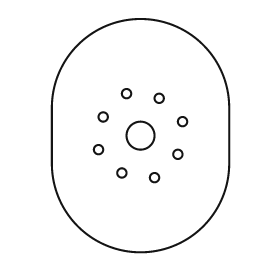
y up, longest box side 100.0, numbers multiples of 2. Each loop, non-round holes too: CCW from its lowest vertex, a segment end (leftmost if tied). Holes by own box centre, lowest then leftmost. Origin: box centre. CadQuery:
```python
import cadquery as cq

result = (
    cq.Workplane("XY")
    .moveTo(-38.0, -12.0)
    .threePointArc((0.0, -50.0), (38.0, -12.0))
    .lineTo(38.0, 12.0)
    .threePointArc((0.0, 50.0), (-38.0, 12.0))
    .close()
    .moveTo(6.0, -18.0)
    .circle(2.0)
    .moveTo(-8.0, -16.0)
    .circle(2.0)
    .moveTo(16.0, -8.0)
    .circle(2.0)
    .moveTo(-18.0, -6.0)
    .circle(2.0)
    .moveTo(0.0, 0.0)
    .circle(6.0)
    .moveTo(18.0, 6.0)
    .circle(2.0)
    .moveTo(-16.0, 8.0)
    .circle(2.0)
    .moveTo(8.0, 16.0)
    .circle(2.0)
    .moveTo(-6.0, 18.0)
    .circle(2.0)
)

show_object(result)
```